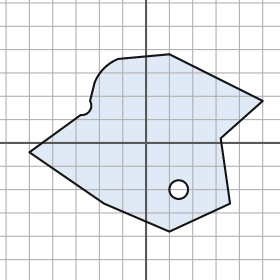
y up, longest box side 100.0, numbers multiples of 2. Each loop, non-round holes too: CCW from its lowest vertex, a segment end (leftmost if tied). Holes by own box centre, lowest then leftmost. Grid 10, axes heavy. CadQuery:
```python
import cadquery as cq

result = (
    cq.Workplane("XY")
    .moveTo(10.0, -38.0)
    .lineTo(36.0, -26.0)
    .lineTo(32.0, 2.0)
    .lineTo(50.0, 18.0)
    .lineTo(10.0, 38.0)
    .lineTo(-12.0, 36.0)
    .threePointArc((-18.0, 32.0), (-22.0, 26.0))
    .lineTo(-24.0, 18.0)
    .threePointArc((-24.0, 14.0), (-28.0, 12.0))
    .lineTo(-50.0, -4.0)
    .lineTo(-18.0, -26.0)
    .close()
    .moveTo(14.0, -20.0)
    .circle(4.0)
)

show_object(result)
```